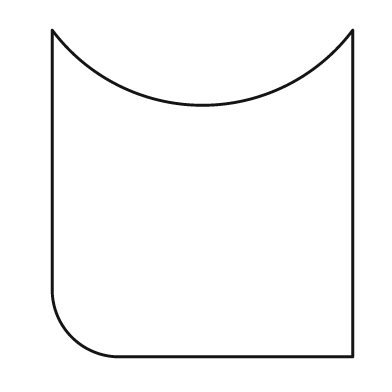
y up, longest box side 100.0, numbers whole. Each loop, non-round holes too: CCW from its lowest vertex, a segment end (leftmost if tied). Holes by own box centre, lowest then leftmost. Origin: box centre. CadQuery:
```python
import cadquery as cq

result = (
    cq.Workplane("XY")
    .moveTo(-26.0, -50.0)
    .lineTo(46.0, -50.0)
    .lineTo(46.0, 50.0)
    .threePointArc((0.0, 27.0), (-46.0, 50.0))
    .lineTo(-46.0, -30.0)
    .threePointArc((-40.0, -44.0), (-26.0, -50.0))
    .close()
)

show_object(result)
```